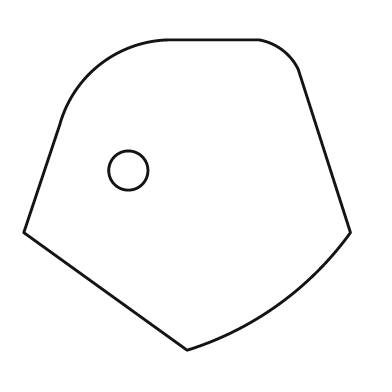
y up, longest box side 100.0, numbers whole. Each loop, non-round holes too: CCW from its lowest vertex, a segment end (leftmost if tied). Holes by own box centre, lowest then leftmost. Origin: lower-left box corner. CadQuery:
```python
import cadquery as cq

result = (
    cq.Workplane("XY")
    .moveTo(50.0, 0.0)
    .threePointArc((78.0, 14.0), (100.0, 36.0))
    .lineTo(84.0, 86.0)
    .threePointArc((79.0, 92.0), (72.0, 95.0))
    .lineTo(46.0, 95.0)
    .threePointArc((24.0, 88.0), (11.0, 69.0))
    .lineTo(0.0, 36.0)
    .close()
    .moveTo(32.0, 55.0)
    .circle(6.0)
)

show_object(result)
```